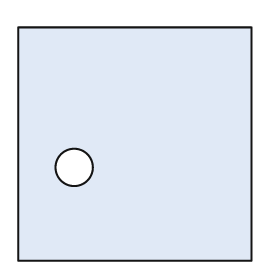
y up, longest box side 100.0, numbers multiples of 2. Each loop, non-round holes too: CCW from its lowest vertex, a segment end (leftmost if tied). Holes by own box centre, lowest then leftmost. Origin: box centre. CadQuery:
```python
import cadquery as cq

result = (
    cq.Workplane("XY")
    .moveTo(-50.0, -50.0)
    .lineTo(50.0, -50.0)
    .lineTo(50.0, 50.0)
    .lineTo(-50.0, 50.0)
    .close()
    .moveTo(-26.0, -10.0)
    .circle(8.0)
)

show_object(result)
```